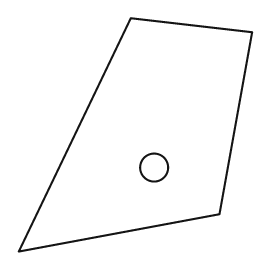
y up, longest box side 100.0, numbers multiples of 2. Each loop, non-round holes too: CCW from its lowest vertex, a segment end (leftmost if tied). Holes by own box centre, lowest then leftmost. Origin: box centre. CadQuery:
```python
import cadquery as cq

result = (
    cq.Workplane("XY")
    .moveTo(-50.0, -50.0)
    .lineTo(36.0, -34.0)
    .lineTo(50.0, 44.0)
    .lineTo(-2.0, 50.0)
    .close()
    .moveTo(8.0, -14.0)
    .circle(6.0)
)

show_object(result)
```